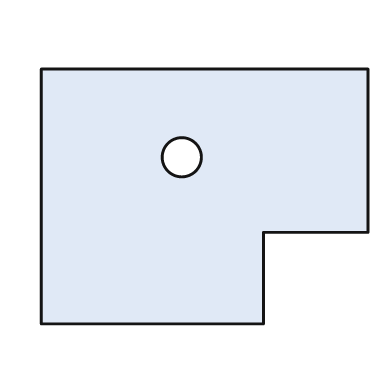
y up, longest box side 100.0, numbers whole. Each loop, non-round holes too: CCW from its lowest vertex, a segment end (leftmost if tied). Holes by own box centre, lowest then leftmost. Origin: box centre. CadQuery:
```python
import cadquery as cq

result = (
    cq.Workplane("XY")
    .moveTo(-50.0, -39.0)
    .lineTo(18.0, -39.0)
    .lineTo(18.0, -11.0)
    .lineTo(50.0, -11.0)
    .lineTo(50.0, 39.0)
    .lineTo(-50.0, 39.0)
    .close()
    .moveTo(-7.0, 12.0)
    .circle(6.0)
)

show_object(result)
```